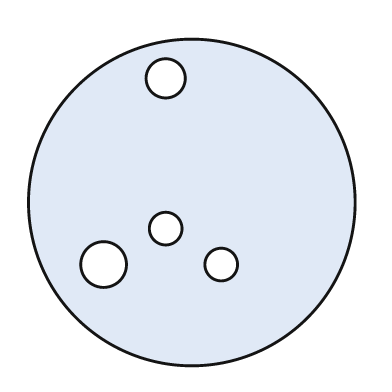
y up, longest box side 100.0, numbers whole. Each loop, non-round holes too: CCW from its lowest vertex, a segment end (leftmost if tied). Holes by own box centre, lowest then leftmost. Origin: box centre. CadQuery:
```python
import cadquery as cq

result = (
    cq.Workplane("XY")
    .moveTo(0.0, 0.0)
    .circle(50.0)
    .moveTo(-27.0, -19.0)
    .circle(7.0)
    .moveTo(9.0, -19.0)
    .circle(5.0)
    .moveTo(-8.0, -8.0)
    .circle(5.0)
    .moveTo(-8.0, 38.0)
    .circle(6.0)
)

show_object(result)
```